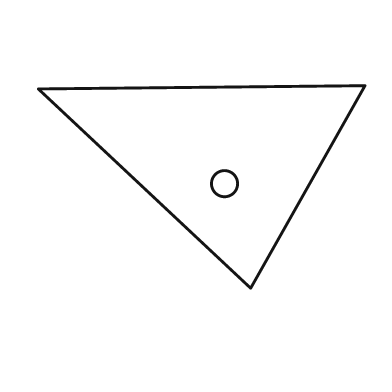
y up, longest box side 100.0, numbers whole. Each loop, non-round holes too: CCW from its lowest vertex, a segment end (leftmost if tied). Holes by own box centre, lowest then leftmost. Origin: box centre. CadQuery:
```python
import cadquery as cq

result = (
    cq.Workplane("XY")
    .moveTo(15.0, -31.0)
    .lineTo(50.0, 31.0)
    .lineTo(-50.0, 30.0)
    .close()
    .moveTo(7.0, 1.0)
    .circle(4.0)
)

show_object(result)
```